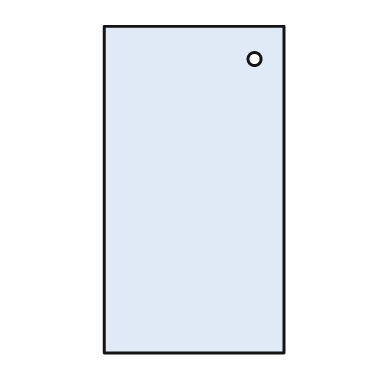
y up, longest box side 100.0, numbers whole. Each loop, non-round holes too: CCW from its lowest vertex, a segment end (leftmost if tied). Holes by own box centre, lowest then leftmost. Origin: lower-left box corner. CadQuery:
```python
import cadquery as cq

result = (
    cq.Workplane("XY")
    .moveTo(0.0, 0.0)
    .lineTo(55.0, 0.0)
    .lineTo(55.0, 100.0)
    .lineTo(0.0, 100.0)
    .close()
    .moveTo(46.0, 90.0)
    .circle(2.0)
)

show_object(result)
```